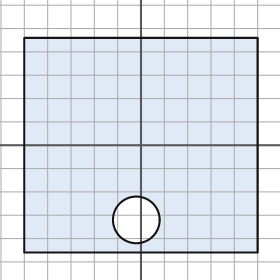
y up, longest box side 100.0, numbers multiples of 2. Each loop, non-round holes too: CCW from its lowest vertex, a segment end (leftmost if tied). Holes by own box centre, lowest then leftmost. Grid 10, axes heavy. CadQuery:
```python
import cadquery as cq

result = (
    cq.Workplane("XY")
    .moveTo(-50.0, -46.0)
    .lineTo(50.0, -46.0)
    .lineTo(50.0, 46.0)
    .lineTo(-50.0, 46.0)
    .close()
    .moveTo(-2.0, -32.0)
    .circle(10.0)
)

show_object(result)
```